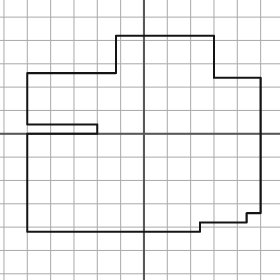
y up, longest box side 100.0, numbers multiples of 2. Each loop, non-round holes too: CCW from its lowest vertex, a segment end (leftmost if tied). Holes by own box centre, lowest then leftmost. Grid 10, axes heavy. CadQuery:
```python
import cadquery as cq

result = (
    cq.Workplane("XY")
    .moveTo(-50.0, -42.0)
    .lineTo(24.0, -42.0)
    .lineTo(24.0, -38.0)
    .lineTo(44.0, -38.0)
    .lineTo(44.0, -34.0)
    .lineTo(50.0, -34.0)
    .lineTo(50.0, 24.0)
    .lineTo(30.0, 24.0)
    .lineTo(30.0, 42.0)
    .lineTo(-12.0, 42.0)
    .lineTo(-12.0, 26.0)
    .lineTo(-50.0, 26.0)
    .lineTo(-50.0, 4.0)
    .lineTo(-20.0, 4.0)
    .lineTo(-20.0, 0.0)
    .lineTo(-50.0, 0.0)
    .close()
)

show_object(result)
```